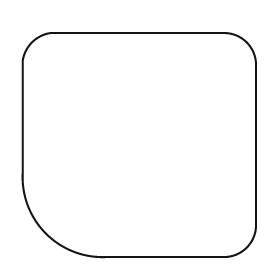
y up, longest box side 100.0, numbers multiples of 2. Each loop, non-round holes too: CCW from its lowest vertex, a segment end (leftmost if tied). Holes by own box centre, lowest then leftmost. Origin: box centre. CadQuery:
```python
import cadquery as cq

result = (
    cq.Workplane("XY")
    .moveTo(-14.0, -48.0)
    .lineTo(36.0, -48.0)
    .threePointArc((46.0, -44.0), (50.0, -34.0))
    .lineTo(50.0, 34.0)
    .threePointArc((46.0, 44.0), (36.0, 48.0))
    .lineTo(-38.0, 48.0)
    .threePointArc((-46.0, 44.0), (-50.0, 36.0))
    .lineTo(-50.0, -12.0)
    .threePointArc((-40.0, -38.0), (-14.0, -48.0))
    .close()
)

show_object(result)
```